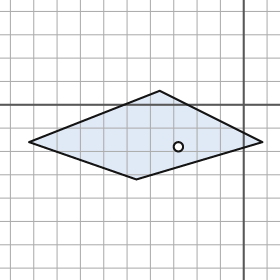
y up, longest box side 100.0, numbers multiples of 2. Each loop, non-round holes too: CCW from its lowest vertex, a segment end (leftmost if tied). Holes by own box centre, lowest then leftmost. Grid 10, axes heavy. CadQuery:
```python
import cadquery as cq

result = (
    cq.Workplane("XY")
    .moveTo(-46.0, -32.0)
    .lineTo(8.0, -16.0)
    .lineTo(-36.0, 6.0)
    .lineTo(-92.0, -16.0)
    .close()
    .moveTo(-28.0, -18.0)
    .circle(2.0)
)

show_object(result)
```